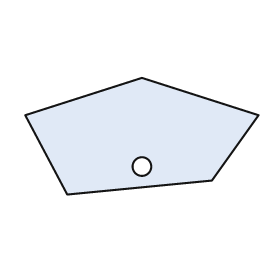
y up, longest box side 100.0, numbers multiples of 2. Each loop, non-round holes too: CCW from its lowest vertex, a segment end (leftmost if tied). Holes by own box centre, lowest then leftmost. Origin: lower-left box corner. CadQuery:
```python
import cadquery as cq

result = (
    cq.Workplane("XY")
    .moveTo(18.0, 0.0)
    .lineTo(80.0, 6.0)
    .lineTo(100.0, 34.0)
    .lineTo(50.0, 50.0)
    .lineTo(0.0, 34.0)
    .close()
    .moveTo(50.0, 12.0)
    .circle(4.0)
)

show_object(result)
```